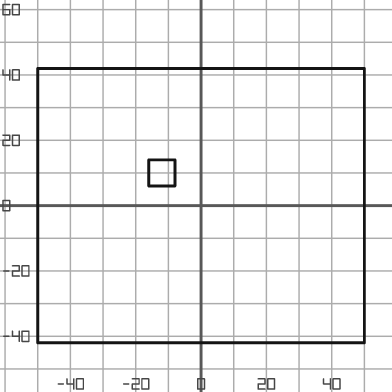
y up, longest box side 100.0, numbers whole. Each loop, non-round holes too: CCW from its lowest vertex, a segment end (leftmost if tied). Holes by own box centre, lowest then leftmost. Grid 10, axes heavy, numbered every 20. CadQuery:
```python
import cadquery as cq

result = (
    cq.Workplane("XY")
    .moveTo(-50.0, -42.0)
    .lineTo(50.0, -42.0)
    .lineTo(50.0, 42.0)
    .lineTo(-50.0, 42.0)
    .close()
    .moveTo(-16.0, 6.0)
    .lineTo(-8.0, 6.0)
    .lineTo(-8.0, 14.0)
    .lineTo(-16.0, 14.0)
    .close()
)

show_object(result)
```